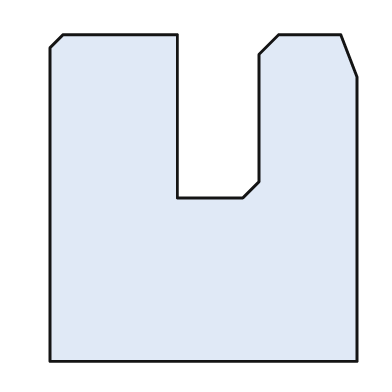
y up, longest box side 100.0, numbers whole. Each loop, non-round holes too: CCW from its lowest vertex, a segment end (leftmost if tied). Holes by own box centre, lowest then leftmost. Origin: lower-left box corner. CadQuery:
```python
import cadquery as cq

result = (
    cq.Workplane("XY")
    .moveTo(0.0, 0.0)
    .lineTo(94.0, 0.0)
    .lineTo(94.0, 87.0)
    .lineTo(89.0, 100.0)
    .lineTo(70.0, 100.0)
    .lineTo(64.0, 94.0)
    .lineTo(64.0, 55.0)
    .lineTo(59.0, 50.0)
    .lineTo(39.0, 50.0)
    .lineTo(39.0, 100.0)
    .lineTo(4.0, 100.0)
    .lineTo(0.0, 96.0)
    .close()
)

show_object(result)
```